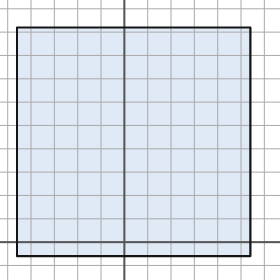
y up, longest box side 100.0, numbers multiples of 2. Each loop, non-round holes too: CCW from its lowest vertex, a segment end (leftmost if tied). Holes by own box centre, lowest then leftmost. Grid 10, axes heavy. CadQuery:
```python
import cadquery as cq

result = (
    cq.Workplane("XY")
    .moveTo(-46.0, -6.0)
    .lineTo(54.0, -6.0)
    .lineTo(54.0, 92.0)
    .lineTo(-46.0, 92.0)
    .close()
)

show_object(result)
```